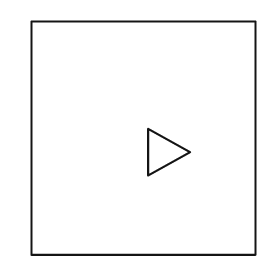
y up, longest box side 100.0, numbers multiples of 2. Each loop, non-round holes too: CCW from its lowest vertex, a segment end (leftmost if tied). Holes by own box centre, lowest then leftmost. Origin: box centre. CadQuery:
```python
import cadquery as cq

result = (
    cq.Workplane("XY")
    .moveTo(-48.0, -50.0)
    .lineTo(48.0, -50.0)
    .lineTo(48.0, 50.0)
    .lineTo(-48.0, 50.0)
    .close()
    .moveTo(2.0, -16.0)
    .lineTo(20.0, -6.0)
    .lineTo(2.0, 4.0)
    .close()
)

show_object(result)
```